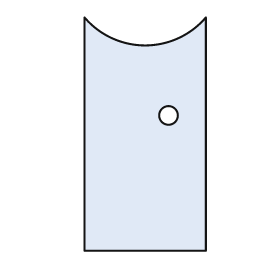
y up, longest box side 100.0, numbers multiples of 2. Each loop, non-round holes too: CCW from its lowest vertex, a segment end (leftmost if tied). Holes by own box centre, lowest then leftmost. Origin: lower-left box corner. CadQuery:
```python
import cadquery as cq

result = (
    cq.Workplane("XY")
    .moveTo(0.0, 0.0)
    .lineTo(52.0, 0.0)
    .lineTo(52.0, 100.0)
    .threePointArc((26.0, 88.0), (0.0, 100.0))
    .close()
    .moveTo(36.0, 58.0)
    .circle(4.0)
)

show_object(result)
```